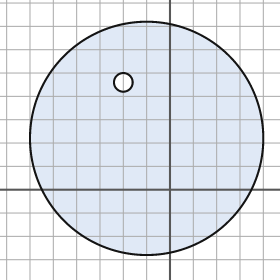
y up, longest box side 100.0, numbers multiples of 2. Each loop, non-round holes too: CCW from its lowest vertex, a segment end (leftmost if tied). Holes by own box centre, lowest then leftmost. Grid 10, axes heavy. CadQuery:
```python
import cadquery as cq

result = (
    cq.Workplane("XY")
    .moveTo(-10.0, 22.0)
    .circle(50.0)
    .moveTo(-20.0, 46.0)
    .circle(4.0)
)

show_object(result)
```